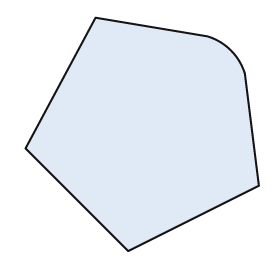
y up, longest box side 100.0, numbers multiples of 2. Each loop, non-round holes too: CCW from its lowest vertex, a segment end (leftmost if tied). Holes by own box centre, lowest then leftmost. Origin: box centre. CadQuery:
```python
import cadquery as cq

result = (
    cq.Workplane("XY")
    .moveTo(-6.0, -50.0)
    .lineTo(50.0, -22.0)
    .lineTo(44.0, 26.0)
    .threePointArc((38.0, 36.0), (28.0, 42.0))
    .lineTo(-20.0, 50.0)
    .lineTo(-50.0, -6.0)
    .close()
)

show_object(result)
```